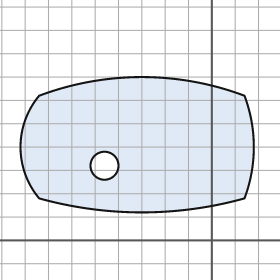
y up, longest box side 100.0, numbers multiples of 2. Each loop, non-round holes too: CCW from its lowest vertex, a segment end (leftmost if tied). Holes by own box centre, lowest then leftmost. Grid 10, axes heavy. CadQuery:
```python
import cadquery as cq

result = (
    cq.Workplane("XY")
    .moveTo(-74.0, 18.0)
    .threePointArc((-30.0, 12.0), (14.0, 18.0))
    .threePointArc((18.0, 40.0), (14.0, 62.0))
    .threePointArc((-30.0, 70.0), (-74.0, 62.0))
    .threePointArc((-82.0, 40.0), (-74.0, 18.0))
    .close()
    .moveTo(-46.0, 32.0)
    .circle(6.0)
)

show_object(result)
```